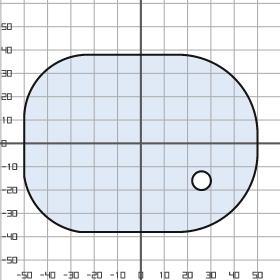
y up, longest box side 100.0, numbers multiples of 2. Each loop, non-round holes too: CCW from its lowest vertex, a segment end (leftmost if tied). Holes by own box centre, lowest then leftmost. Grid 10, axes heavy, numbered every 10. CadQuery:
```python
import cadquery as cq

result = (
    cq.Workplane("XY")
    .moveTo(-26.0, -38.0)
    .lineTo(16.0, -38.0)
    .threePointArc((40.0, -28.0), (50.0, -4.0))
    .lineTo(50.0, 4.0)
    .threePointArc((40.0, 28.0), (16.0, 38.0))
    .lineTo(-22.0, 38.0)
    .threePointArc((-42.0, 30.0), (-50.0, 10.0))
    .lineTo(-50.0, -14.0)
    .threePointArc((-42.0, -30.0), (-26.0, -38.0))
    .close()
    .moveTo(26.0, -16.0)
    .circle(4.0)
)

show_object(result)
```